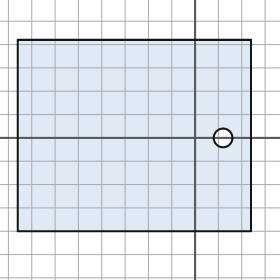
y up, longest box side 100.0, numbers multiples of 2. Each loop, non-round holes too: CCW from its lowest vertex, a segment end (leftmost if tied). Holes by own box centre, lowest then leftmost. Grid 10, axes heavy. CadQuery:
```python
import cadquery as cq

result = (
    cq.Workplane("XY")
    .moveTo(-76.0, -40.0)
    .lineTo(24.0, -40.0)
    .lineTo(24.0, 42.0)
    .lineTo(-76.0, 42.0)
    .close()
    .moveTo(12.0, 0.0)
    .circle(4.0)
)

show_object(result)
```